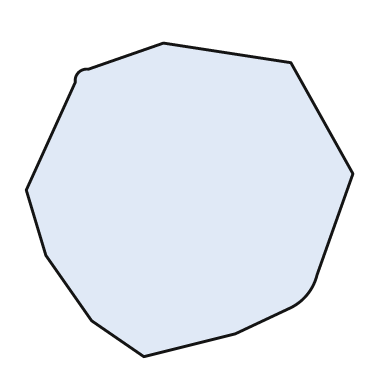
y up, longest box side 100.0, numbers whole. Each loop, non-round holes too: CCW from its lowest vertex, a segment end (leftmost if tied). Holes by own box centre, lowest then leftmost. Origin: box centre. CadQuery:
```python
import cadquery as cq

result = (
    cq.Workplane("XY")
    .moveTo(-14.0, -48.0)
    .lineTo(14.0, -41.0)
    .lineTo(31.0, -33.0)
    .threePointArc((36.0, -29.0), (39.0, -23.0))
    .lineTo(50.0, 8.0)
    .lineTo(31.0, 42.0)
    .lineTo(-8.0, 48.0)
    .lineTo(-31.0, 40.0)
    .threePointArc((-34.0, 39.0), (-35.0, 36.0))
    .lineTo(-50.0, 3.0)
    .lineTo(-44.0, -17.0)
    .lineTo(-30.0, -37.0)
    .close()
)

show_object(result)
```